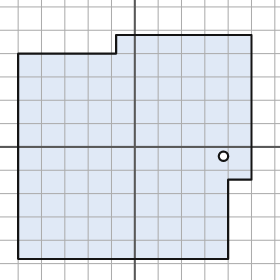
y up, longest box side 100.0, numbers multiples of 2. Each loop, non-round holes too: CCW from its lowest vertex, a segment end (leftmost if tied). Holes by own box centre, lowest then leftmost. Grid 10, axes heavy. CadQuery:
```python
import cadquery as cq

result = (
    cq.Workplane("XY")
    .moveTo(-50.0, -48.0)
    .lineTo(40.0, -48.0)
    .lineTo(40.0, -14.0)
    .lineTo(50.0, -14.0)
    .lineTo(50.0, 48.0)
    .lineTo(-8.0, 48.0)
    .lineTo(-8.0, 40.0)
    .lineTo(-50.0, 40.0)
    .close()
    .moveTo(38.0, -4.0)
    .circle(2.0)
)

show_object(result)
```